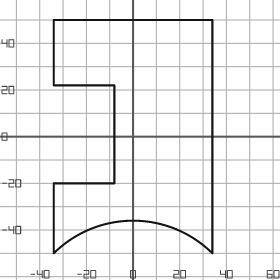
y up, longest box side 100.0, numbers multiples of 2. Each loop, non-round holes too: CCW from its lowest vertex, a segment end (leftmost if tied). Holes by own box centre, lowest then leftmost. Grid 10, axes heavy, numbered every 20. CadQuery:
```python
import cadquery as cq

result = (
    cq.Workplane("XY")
    .moveTo(-34.0, -50.0)
    .threePointArc((0.0, -36.0), (34.0, -50.0))
    .lineTo(34.0, 50.0)
    .lineTo(-34.0, 50.0)
    .lineTo(-34.0, 22.0)
    .lineTo(-8.0, 22.0)
    .lineTo(-8.0, -20.0)
    .lineTo(-34.0, -20.0)
    .close()
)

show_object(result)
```